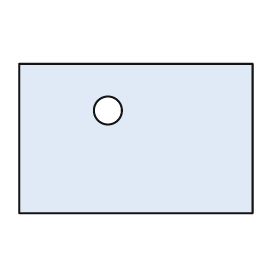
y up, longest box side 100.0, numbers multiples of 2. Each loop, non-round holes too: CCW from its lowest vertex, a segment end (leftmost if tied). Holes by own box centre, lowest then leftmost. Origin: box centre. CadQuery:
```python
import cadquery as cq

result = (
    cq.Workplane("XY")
    .moveTo(-50.0, -32.0)
    .lineTo(50.0, -32.0)
    .lineTo(50.0, 32.0)
    .lineTo(-50.0, 32.0)
    .close()
    .moveTo(-12.0, 12.0)
    .circle(6.0)
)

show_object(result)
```